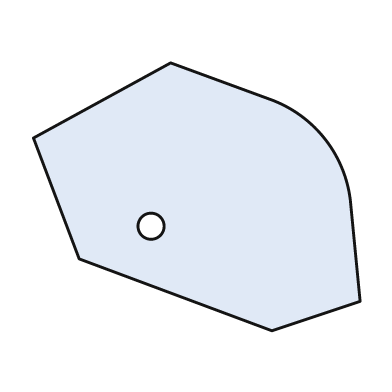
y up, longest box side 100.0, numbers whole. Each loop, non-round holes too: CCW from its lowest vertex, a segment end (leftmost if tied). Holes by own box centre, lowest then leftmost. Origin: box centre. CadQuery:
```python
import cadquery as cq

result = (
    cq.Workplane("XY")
    .moveTo(23.0, -41.0)
    .lineTo(50.0, -32.0)
    .lineTo(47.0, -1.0)
    .threePointArc((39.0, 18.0), (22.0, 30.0))
    .lineTo(-8.0, 41.0)
    .lineTo(-50.0, 18.0)
    .lineTo(-36.0, -19.0)
    .close()
    .moveTo(-14.0, -9.0)
    .circle(4.0)
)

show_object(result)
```